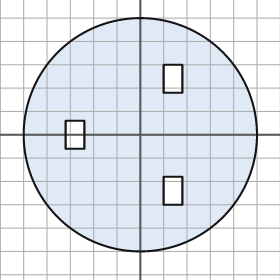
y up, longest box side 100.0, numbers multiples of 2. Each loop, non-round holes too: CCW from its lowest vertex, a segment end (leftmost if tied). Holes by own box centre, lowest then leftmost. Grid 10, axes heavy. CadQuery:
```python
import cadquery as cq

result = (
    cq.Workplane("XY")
    .moveTo(0.0, 0.0)
    .circle(50.0)
    .moveTo(10.0, -30.0)
    .lineTo(18.0, -30.0)
    .lineTo(18.0, -18.0)
    .lineTo(10.0, -18.0)
    .close()
    .moveTo(-32.0, -6.0)
    .lineTo(-24.0, -6.0)
    .lineTo(-24.0, 6.0)
    .lineTo(-32.0, 6.0)
    .close()
    .moveTo(10.0, 18.0)
    .lineTo(18.0, 18.0)
    .lineTo(18.0, 30.0)
    .lineTo(10.0, 30.0)
    .close()
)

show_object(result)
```